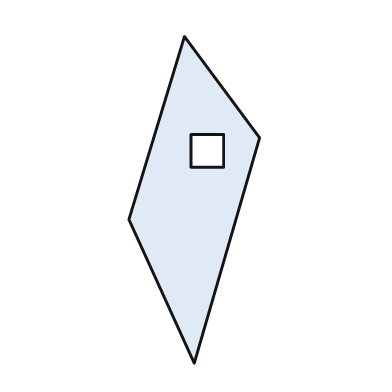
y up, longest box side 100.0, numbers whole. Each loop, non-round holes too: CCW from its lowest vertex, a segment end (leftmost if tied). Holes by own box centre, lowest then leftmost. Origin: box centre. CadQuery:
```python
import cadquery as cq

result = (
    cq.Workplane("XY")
    .moveTo(0.0, -50.0)
    .lineTo(20.0, 19.0)
    .lineTo(-3.0, 50.0)
    .lineTo(-20.0, -6.0)
    .close()
    .moveTo(-1.0, 10.0)
    .lineTo(9.0, 10.0)
    .lineTo(9.0, 20.0)
    .lineTo(-1.0, 20.0)
    .close()
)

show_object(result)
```